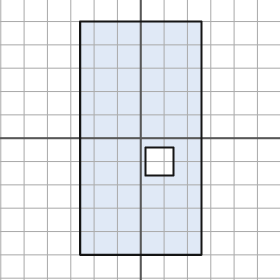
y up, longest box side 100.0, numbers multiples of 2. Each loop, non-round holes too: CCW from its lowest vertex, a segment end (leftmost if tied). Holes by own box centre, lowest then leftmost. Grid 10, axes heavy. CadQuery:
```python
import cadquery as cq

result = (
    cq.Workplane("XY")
    .moveTo(-26.0, -50.0)
    .lineTo(26.0, -50.0)
    .lineTo(26.0, 50.0)
    .lineTo(-26.0, 50.0)
    .close()
    .moveTo(2.0, -16.0)
    .lineTo(14.0, -16.0)
    .lineTo(14.0, -4.0)
    .lineTo(2.0, -4.0)
    .close()
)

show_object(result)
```